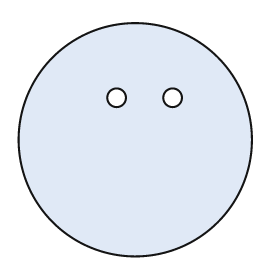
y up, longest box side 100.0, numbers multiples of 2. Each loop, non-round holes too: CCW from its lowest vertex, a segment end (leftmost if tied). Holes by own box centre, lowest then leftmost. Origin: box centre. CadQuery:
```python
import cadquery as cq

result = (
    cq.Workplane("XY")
    .moveTo(0.0, 0.0)
    .circle(50.0)
    .moveTo(-8.0, 18.0)
    .circle(4.0)
    .moveTo(16.0, 18.0)
    .circle(4.0)
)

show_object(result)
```